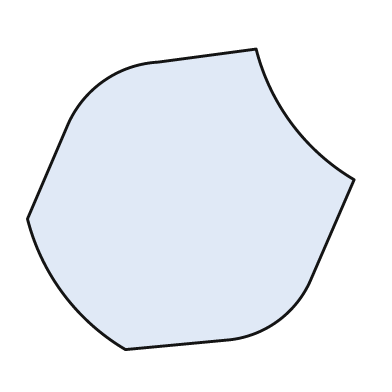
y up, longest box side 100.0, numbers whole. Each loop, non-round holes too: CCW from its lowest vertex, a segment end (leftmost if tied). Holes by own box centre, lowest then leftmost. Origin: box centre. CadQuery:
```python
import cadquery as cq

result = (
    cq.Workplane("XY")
    .moveTo(-20.0, -46.0)
    .lineTo(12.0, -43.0)
    .threePointArc((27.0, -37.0), (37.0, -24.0))
    .lineTo(50.0, 6.0)
    .threePointArc((31.0, 23.0), (20.0, 46.0))
    .lineTo(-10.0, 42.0)
    .threePointArc((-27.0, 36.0), (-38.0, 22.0))
    .lineTo(-50.0, -6.0)
    .threePointArc((-39.0, -29.0), (-20.0, -46.0))
    .close()
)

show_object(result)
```